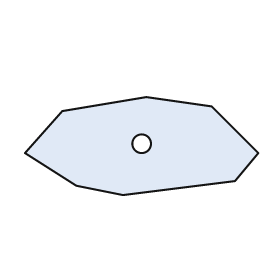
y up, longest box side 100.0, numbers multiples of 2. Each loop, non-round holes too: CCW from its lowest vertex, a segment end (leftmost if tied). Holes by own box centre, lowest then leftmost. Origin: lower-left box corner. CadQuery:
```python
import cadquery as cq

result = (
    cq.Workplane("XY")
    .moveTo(42.0, 0.0)
    .lineTo(90.0, 6.0)
    .lineTo(100.0, 18.0)
    .lineTo(80.0, 38.0)
    .lineTo(52.0, 42.0)
    .lineTo(16.0, 36.0)
    .lineTo(0.0, 18.0)
    .lineTo(22.0, 4.0)
    .close()
    .moveTo(50.0, 22.0)
    .circle(4.0)
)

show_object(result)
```